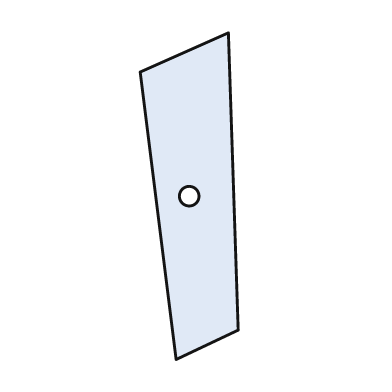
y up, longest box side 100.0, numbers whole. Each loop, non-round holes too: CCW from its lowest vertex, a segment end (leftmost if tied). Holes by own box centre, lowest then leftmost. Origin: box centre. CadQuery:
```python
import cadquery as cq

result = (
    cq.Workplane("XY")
    .moveTo(-4.0, -50.0)
    .lineTo(15.0, -41.0)
    .lineTo(12.0, 50.0)
    .lineTo(-15.0, 38.0)
    .close()
    .moveTo(0.0, 0.0)
    .circle(3.0)
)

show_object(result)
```